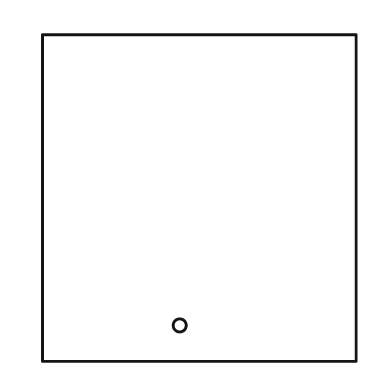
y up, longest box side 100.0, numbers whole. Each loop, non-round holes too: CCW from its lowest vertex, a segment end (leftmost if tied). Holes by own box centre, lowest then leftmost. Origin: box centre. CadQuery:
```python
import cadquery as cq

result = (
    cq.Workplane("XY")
    .moveTo(-48.0, -50.0)
    .lineTo(48.0, -50.0)
    .lineTo(48.0, 50.0)
    .lineTo(-48.0, 50.0)
    .close()
    .moveTo(-6.0, -39.0)
    .circle(2.0)
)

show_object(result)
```